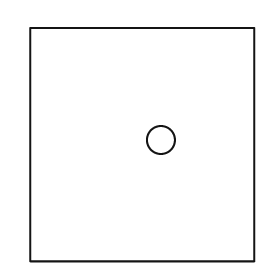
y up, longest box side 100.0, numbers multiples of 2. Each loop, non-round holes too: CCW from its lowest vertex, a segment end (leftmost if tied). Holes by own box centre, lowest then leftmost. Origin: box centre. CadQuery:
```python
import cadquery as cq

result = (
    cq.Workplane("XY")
    .moveTo(-48.0, -50.0)
    .lineTo(48.0, -50.0)
    .lineTo(48.0, 50.0)
    .lineTo(-48.0, 50.0)
    .close()
    .moveTo(8.0, 2.0)
    .circle(6.0)
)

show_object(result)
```